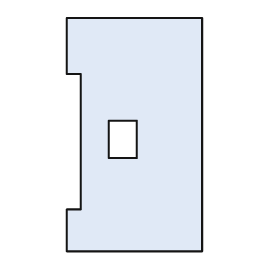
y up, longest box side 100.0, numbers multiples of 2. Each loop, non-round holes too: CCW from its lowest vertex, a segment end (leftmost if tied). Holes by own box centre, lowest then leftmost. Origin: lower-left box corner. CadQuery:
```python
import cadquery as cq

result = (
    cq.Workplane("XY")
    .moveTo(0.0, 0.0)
    .lineTo(58.0, 0.0)
    .lineTo(58.0, 100.0)
    .lineTo(0.0, 100.0)
    .lineTo(0.0, 76.0)
    .lineTo(6.0, 76.0)
    .lineTo(6.0, 18.0)
    .lineTo(0.0, 18.0)
    .close()
    .moveTo(18.0, 40.0)
    .lineTo(30.0, 40.0)
    .lineTo(30.0, 56.0)
    .lineTo(18.0, 56.0)
    .close()
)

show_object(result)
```